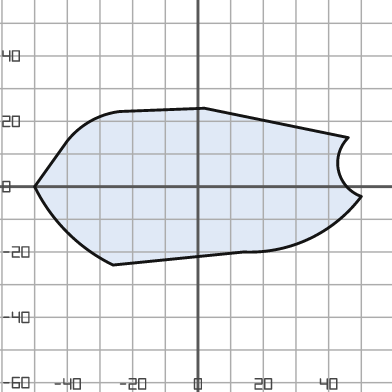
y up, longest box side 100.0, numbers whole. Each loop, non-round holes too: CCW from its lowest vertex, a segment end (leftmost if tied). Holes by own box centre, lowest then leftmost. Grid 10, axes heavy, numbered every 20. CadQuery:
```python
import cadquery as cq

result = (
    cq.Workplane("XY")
    .moveTo(-26.0, -24.0)
    .lineTo(14.0, -20.0)
    .threePointArc((34.0, -16.0), (50.0, -3.0))
    .threePointArc((43.0, 5.0), (46.0, 15.0))
    .lineTo(2.0, 24.0)
    .lineTo(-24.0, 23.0)
    .threePointArc((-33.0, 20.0), (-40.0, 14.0))
    .lineTo(-50.0, 0.0)
    .threePointArc((-40.0, -14.0), (-26.0, -24.0))
    .close()
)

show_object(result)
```